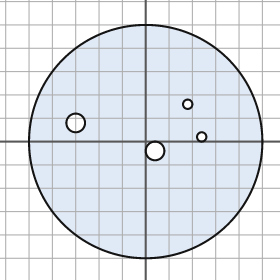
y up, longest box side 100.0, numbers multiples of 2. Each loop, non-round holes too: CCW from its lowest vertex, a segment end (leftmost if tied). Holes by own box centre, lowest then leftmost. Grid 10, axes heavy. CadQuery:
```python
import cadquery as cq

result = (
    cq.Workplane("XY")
    .moveTo(0.0, 0.0)
    .circle(50.0)
    .moveTo(4.0, -4.0)
    .circle(4.0)
    .moveTo(24.0, 2.0)
    .circle(2.0)
    .moveTo(-30.0, 8.0)
    .circle(4.0)
    .moveTo(18.0, 16.0)
    .circle(2.0)
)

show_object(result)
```